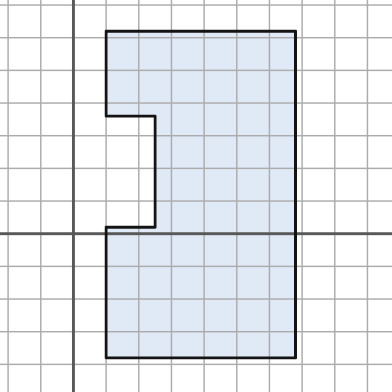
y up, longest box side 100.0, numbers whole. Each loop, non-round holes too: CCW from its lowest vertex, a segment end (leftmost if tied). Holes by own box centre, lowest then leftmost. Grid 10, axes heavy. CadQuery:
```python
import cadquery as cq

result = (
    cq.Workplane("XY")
    .moveTo(10.0, -38.0)
    .lineTo(68.0, -38.0)
    .lineTo(68.0, 62.0)
    .lineTo(10.0, 62.0)
    .lineTo(10.0, 36.0)
    .lineTo(25.0, 36.0)
    .lineTo(25.0, 2.0)
    .lineTo(10.0, 2.0)
    .close()
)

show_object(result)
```